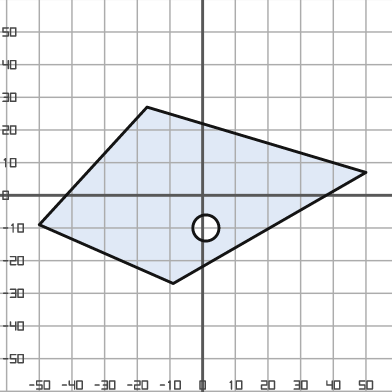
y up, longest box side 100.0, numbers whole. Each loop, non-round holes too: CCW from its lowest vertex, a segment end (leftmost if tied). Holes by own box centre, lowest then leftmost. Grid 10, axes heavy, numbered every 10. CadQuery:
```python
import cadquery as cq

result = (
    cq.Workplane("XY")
    .moveTo(-9.0, -27.0)
    .lineTo(50.0, 7.0)
    .lineTo(-17.0, 27.0)
    .lineTo(-50.0, -9.0)
    .close()
    .moveTo(1.0, -10.0)
    .circle(4.0)
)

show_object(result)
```